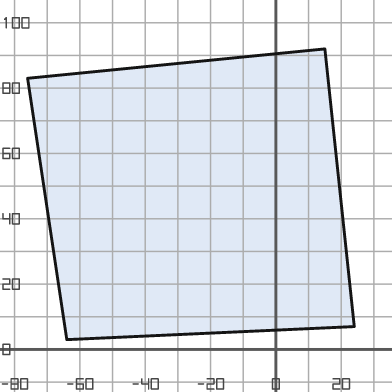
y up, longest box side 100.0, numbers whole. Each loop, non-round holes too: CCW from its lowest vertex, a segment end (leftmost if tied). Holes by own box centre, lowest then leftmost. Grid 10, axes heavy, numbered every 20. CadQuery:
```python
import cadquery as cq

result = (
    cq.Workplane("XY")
    .moveTo(-64.0, 3.0)
    .lineTo(24.0, 7.0)
    .lineTo(15.0, 92.0)
    .lineTo(-76.0, 83.0)
    .close()
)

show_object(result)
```